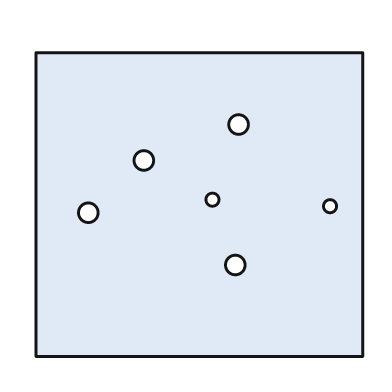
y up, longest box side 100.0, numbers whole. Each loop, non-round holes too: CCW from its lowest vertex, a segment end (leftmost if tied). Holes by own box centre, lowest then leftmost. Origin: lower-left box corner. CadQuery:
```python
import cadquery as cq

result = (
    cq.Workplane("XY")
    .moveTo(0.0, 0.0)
    .lineTo(100.0, 0.0)
    .lineTo(100.0, 93.0)
    .lineTo(0.0, 93.0)
    .close()
    .moveTo(61.0, 28.0)
    .circle(3.0)
    .moveTo(16.0, 44.0)
    .circle(3.0)
    .moveTo(90.0, 46.0)
    .circle(2.0)
    .moveTo(54.0, 48.0)
    .circle(2.0)
    .moveTo(33.0, 60.0)
    .circle(3.0)
    .moveTo(62.0, 71.0)
    .circle(3.0)
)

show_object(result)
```